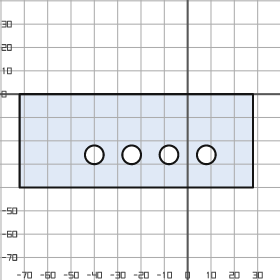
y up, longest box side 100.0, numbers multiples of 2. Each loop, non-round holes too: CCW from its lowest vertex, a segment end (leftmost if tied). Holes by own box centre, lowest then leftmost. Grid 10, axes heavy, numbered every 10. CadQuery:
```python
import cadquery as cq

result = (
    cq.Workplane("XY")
    .moveTo(-72.0, -40.0)
    .lineTo(28.0, -40.0)
    .lineTo(28.0, 0.0)
    .lineTo(-72.0, 0.0)
    .close()
    .moveTo(-40.0, -26.0)
    .circle(4.0)
    .moveTo(-24.0, -26.0)
    .circle(4.0)
    .moveTo(-8.0, -26.0)
    .circle(4.0)
    .moveTo(8.0, -26.0)
    .circle(4.0)
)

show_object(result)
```